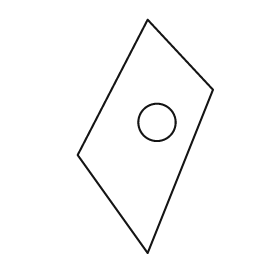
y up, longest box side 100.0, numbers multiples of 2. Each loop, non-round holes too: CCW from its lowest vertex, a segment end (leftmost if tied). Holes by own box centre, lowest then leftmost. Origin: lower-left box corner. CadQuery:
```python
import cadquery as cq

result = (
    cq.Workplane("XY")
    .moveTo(30.0, 0.0)
    .lineTo(58.0, 70.0)
    .lineTo(30.0, 100.0)
    .lineTo(0.0, 42.0)
    .close()
    .moveTo(34.0, 56.0)
    .circle(8.0)
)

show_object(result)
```